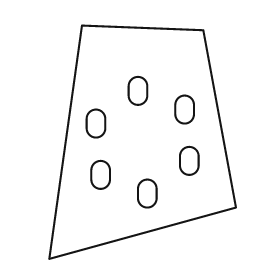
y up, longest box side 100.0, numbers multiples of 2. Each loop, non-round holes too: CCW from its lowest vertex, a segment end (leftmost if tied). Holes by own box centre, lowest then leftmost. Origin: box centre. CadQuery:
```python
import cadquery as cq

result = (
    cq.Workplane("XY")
    .moveTo(-40.0, -50.0)
    .lineTo(40.0, -28.0)
    .lineTo(26.0, 48.0)
    .lineTo(-26.0, 50.0)
    .close()
    .moveTo(-2.0, -24.0)
    .threePointArc((2.0, -28.0), (6.0, -24.0))
    .lineTo(6.0, -20.0)
    .threePointArc((2.0, -16.0), (-2.0, -20.0))
    .close()
    .moveTo(-22.0, -16.0)
    .threePointArc((-18.0, -20.0), (-14.0, -16.0))
    .lineTo(-14.0, -12.0)
    .threePointArc((-18.0, -8.0), (-22.0, -12.0))
    .close()
    .moveTo(16.0, -10.0)
    .threePointArc((20.0, -14.0), (24.0, -10.0))
    .lineTo(24.0, -6.0)
    .threePointArc((20.0, -2.0), (16.0, -6.0))
    .close()
    .moveTo(-24.0, 6.0)
    .threePointArc((-20.0, 2.0), (-16.0, 6.0))
    .lineTo(-16.0, 10.0)
    .threePointArc((-20.0, 14.0), (-24.0, 10.0))
    .close()
    .moveTo(14.0, 12.0)
    .threePointArc((18.0, 8.0), (22.0, 12.0))
    .lineTo(22.0, 16.0)
    .threePointArc((18.0, 20.0), (14.0, 16.0))
    .close()
    .moveTo(-6.0, 20.0)
    .threePointArc((-2.0, 16.0), (2.0, 20.0))
    .lineTo(2.0, 24.0)
    .threePointArc((-2.0, 28.0), (-6.0, 24.0))
    .close()
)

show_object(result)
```